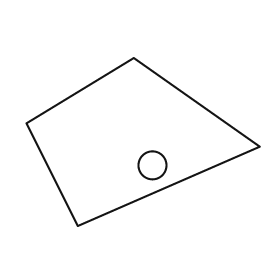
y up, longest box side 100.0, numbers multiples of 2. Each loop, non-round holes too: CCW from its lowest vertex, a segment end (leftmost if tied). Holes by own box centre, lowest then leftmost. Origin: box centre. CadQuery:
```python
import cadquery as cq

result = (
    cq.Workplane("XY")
    .moveTo(-28.0, -36.0)
    .lineTo(50.0, -2.0)
    .lineTo(-4.0, 36.0)
    .lineTo(-50.0, 8.0)
    .close()
    .moveTo(4.0, -10.0)
    .circle(6.0)
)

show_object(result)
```